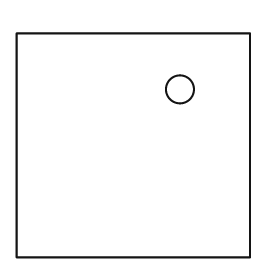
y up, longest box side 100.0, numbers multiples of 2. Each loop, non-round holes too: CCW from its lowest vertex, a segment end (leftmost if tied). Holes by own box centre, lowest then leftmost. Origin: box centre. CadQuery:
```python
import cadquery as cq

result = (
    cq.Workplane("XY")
    .moveTo(-50.0, -48.0)
    .lineTo(50.0, -48.0)
    .lineTo(50.0, 48.0)
    .lineTo(-50.0, 48.0)
    .close()
    .moveTo(20.0, 24.0)
    .circle(6.0)
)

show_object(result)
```